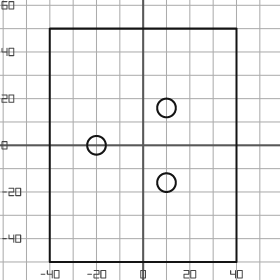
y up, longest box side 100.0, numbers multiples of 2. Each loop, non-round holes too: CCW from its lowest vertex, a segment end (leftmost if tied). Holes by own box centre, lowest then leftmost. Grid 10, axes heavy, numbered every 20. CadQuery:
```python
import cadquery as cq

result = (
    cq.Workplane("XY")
    .moveTo(-40.0, -50.0)
    .lineTo(40.0, -50.0)
    .lineTo(40.0, 50.0)
    .lineTo(-40.0, 50.0)
    .close()
    .moveTo(10.0, -16.0)
    .circle(4.0)
    .moveTo(-20.0, 0.0)
    .circle(4.0)
    .moveTo(10.0, 16.0)
    .circle(4.0)
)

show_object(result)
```